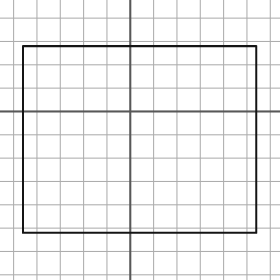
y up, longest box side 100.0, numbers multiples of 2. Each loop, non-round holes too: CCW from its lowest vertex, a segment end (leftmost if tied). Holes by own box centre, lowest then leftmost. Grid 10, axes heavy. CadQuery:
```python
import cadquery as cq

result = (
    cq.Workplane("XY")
    .moveTo(-46.0, -52.0)
    .lineTo(54.0, -52.0)
    .lineTo(54.0, 28.0)
    .lineTo(-46.0, 28.0)
    .close()
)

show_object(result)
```